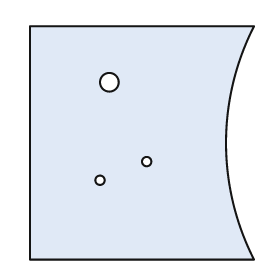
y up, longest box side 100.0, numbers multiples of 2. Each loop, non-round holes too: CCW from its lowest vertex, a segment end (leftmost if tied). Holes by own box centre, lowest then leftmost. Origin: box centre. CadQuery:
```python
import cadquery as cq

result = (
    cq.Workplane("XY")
    .moveTo(-48.0, -50.0)
    .lineTo(48.0, -50.0)
    .threePointArc((36.0, 0.0), (48.0, 50.0))
    .lineTo(-48.0, 50.0)
    .close()
    .moveTo(-18.0, -16.0)
    .circle(2.0)
    .moveTo(2.0, -8.0)
    .circle(2.0)
    .moveTo(-14.0, 26.0)
    .circle(4.0)
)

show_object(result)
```